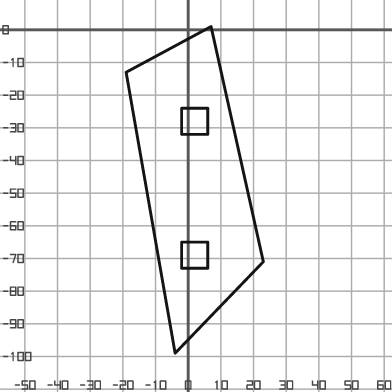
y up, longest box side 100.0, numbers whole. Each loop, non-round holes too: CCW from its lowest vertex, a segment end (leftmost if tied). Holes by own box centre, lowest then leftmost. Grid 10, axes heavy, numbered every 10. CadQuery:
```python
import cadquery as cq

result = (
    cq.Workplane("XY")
    .moveTo(-4.0, -99.0)
    .lineTo(23.0, -71.0)
    .lineTo(7.0, 1.0)
    .lineTo(-19.0, -13.0)
    .close()
    .moveTo(-2.0, -73.0)
    .lineTo(6.0, -73.0)
    .lineTo(6.0, -65.0)
    .lineTo(-2.0, -65.0)
    .close()
    .moveTo(-2.0, -32.0)
    .lineTo(6.0, -32.0)
    .lineTo(6.0, -24.0)
    .lineTo(-2.0, -24.0)
    .close()
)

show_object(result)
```